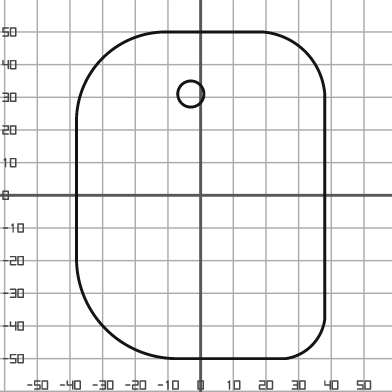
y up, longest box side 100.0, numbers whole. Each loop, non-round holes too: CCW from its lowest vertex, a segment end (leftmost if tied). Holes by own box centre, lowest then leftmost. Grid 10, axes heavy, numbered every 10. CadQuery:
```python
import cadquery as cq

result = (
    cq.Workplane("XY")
    .moveTo(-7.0, -50.0)
    .lineTo(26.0, -50.0)
    .threePointArc((34.0, -46.0), (38.0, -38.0))
    .lineTo(38.0, 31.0)
    .threePointArc((32.0, 44.0), (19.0, 50.0))
    .lineTo(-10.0, 50.0)
    .threePointArc((-30.0, 42.0), (-38.0, 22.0))
    .lineTo(-38.0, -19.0)
    .threePointArc((-29.0, -41.0), (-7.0, -50.0))
    .close()
    .moveTo(-3.0, 31.0)
    .circle(4.0)
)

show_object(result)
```